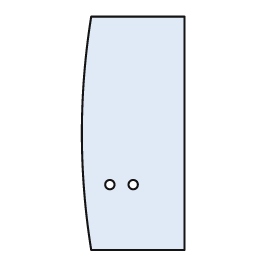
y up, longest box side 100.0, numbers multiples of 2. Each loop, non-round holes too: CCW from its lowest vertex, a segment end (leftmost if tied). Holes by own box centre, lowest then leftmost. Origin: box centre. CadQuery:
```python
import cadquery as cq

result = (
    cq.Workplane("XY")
    .moveTo(-18.0, -50.0)
    .lineTo(22.0, -50.0)
    .lineTo(22.0, 50.0)
    .lineTo(-18.0, 50.0)
    .threePointArc((-22.0, 0.0), (-18.0, -50.0))
    .close()
    .moveTo(-10.0, -22.0)
    .circle(2.0)
    .moveTo(0.0, -22.0)
    .circle(2.0)
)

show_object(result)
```